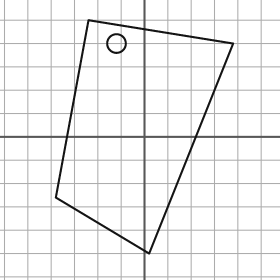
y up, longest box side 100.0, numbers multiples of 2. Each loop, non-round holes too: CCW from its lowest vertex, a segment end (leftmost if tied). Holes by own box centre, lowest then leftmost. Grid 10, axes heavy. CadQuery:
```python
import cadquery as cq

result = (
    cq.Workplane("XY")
    .moveTo(2.0, -50.0)
    .lineTo(38.0, 40.0)
    .lineTo(-24.0, 50.0)
    .lineTo(-38.0, -26.0)
    .close()
    .moveTo(-12.0, 40.0)
    .circle(4.0)
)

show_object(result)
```